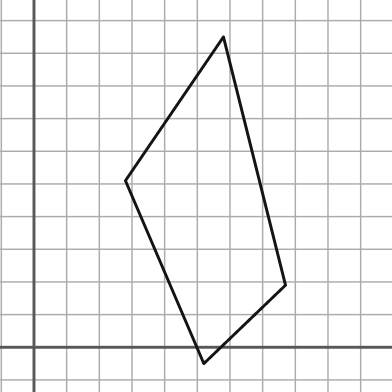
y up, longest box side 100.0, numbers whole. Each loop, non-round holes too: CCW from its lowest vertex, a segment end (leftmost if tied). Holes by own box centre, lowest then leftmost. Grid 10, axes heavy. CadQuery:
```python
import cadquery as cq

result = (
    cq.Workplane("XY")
    .moveTo(52.0, -5.0)
    .lineTo(77.0, 19.0)
    .lineTo(58.0, 95.0)
    .lineTo(28.0, 51.0)
    .close()
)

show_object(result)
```